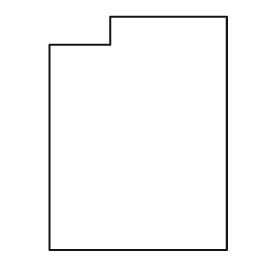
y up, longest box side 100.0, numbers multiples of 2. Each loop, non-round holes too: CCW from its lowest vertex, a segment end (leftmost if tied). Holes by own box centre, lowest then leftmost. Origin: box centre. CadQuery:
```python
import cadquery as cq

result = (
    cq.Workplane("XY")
    .moveTo(-38.0, -50.0)
    .lineTo(38.0, -50.0)
    .lineTo(38.0, 50.0)
    .lineTo(-12.0, 50.0)
    .lineTo(-12.0, 38.0)
    .lineTo(-38.0, 38.0)
    .close()
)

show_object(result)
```